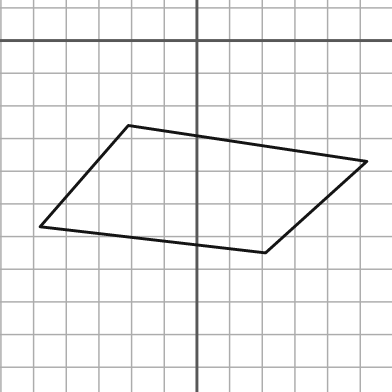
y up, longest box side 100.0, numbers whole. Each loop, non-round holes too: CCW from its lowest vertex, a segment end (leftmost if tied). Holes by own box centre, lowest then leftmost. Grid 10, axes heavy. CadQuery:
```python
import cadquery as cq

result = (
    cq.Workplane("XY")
    .moveTo(21.0, -65.0)
    .lineTo(52.0, -37.0)
    .lineTo(-21.0, -26.0)
    .lineTo(-48.0, -57.0)
    .close()
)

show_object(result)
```